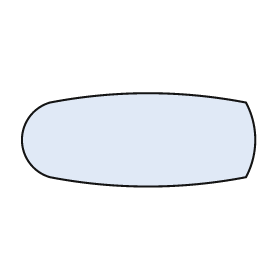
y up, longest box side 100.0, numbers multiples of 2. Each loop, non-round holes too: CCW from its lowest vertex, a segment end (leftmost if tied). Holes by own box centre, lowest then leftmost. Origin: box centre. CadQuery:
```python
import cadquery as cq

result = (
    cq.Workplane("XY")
    .moveTo(-38.0, -16.0)
    .threePointArc((4.0, -20.0), (46.0, -16.0))
    .threePointArc((50.0, 0.0), (46.0, 16.0))
    .threePointArc((4.0, 20.0), (-38.0, 16.0))
    .threePointArc((-50.0, 0.0), (-38.0, -16.0))
    .close()
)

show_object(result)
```